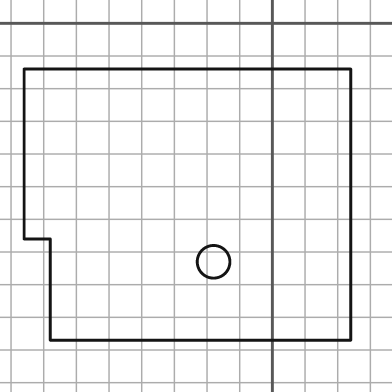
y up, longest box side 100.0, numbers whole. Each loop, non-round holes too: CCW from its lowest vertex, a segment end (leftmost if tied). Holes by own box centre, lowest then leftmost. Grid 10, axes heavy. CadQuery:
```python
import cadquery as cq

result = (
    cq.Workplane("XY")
    .moveTo(-68.0, -97.0)
    .lineTo(24.0, -97.0)
    .lineTo(24.0, -14.0)
    .lineTo(-76.0, -14.0)
    .lineTo(-76.0, -66.0)
    .lineTo(-68.0, -66.0)
    .close()
    .moveTo(-18.0, -73.0)
    .circle(5.0)
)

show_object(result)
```